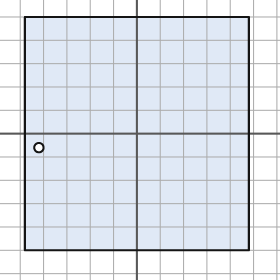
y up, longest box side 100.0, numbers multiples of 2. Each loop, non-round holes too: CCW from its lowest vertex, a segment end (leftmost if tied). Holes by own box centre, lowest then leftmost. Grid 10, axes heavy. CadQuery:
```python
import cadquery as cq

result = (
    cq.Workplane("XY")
    .moveTo(-48.0, -50.0)
    .lineTo(48.0, -50.0)
    .lineTo(48.0, 50.0)
    .lineTo(-48.0, 50.0)
    .close()
    .moveTo(-42.0, -6.0)
    .circle(2.0)
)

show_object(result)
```